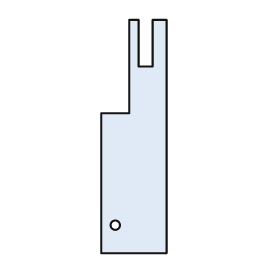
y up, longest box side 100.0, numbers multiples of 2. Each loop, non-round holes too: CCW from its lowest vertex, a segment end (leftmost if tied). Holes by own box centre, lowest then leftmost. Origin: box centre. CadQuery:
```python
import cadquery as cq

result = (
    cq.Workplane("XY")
    .moveTo(-14.0, -50.0)
    .lineTo(14.0, -50.0)
    .lineTo(14.0, 50.0)
    .lineTo(8.0, 50.0)
    .lineTo(8.0, 30.0)
    .lineTo(2.0, 30.0)
    .lineTo(2.0, 50.0)
    .lineTo(-2.0, 50.0)
    .lineTo(-2.0, 10.0)
    .lineTo(-14.0, 10.0)
    .close()
    .moveTo(-8.0, -38.0)
    .circle(2.0)
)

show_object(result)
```